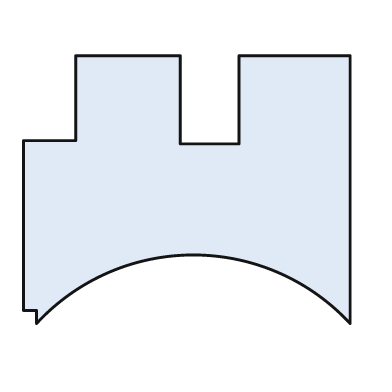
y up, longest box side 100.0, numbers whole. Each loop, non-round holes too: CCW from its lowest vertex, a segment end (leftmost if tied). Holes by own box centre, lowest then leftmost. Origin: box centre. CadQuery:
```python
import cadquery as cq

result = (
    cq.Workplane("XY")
    .moveTo(-46.0, -41.0)
    .threePointArc((2.0, -20.0), (50.0, -41.0))
    .lineTo(50.0, 41.0)
    .lineTo(16.0, 41.0)
    .lineTo(16.0, 14.0)
    .lineTo(-2.0, 14.0)
    .lineTo(-2.0, 41.0)
    .lineTo(-34.0, 41.0)
    .lineTo(-34.0, 15.0)
    .lineTo(-50.0, 15.0)
    .lineTo(-50.0, -37.0)
    .lineTo(-46.0, -37.0)
    .close()
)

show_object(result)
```